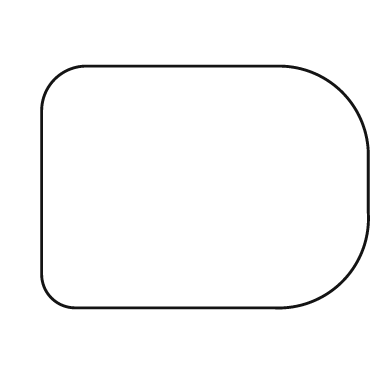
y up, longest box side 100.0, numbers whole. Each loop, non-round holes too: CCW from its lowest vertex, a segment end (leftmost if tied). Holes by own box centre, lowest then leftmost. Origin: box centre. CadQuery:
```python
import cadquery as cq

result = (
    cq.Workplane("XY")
    .moveTo(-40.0, -37.0)
    .lineTo(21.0, -37.0)
    .threePointArc((42.0, -29.0), (50.0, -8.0))
    .lineTo(50.0, 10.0)
    .threePointArc((42.0, 29.0), (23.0, 37.0))
    .lineTo(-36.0, 37.0)
    .threePointArc((-46.0, 33.0), (-50.0, 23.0))
    .lineTo(-50.0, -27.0)
    .threePointArc((-47.0, -34.0), (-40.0, -37.0))
    .close()
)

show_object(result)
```